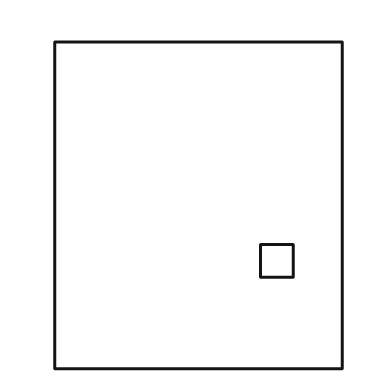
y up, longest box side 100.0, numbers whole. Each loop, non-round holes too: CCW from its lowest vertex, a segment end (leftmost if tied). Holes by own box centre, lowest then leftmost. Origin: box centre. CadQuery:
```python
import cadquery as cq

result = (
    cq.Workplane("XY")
    .moveTo(-44.0, -50.0)
    .lineTo(44.0, -50.0)
    .lineTo(44.0, 50.0)
    .lineTo(-44.0, 50.0)
    .close()
    .moveTo(19.0, -22.0)
    .lineTo(29.0, -22.0)
    .lineTo(29.0, -12.0)
    .lineTo(19.0, -12.0)
    .close()
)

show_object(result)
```